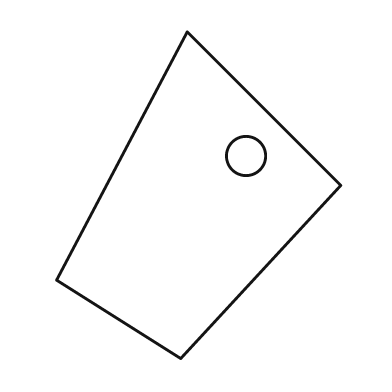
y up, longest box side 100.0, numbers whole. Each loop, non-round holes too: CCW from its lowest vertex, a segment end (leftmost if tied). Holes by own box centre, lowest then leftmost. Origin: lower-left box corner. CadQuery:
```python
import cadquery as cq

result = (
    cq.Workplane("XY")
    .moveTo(38.0, 0.0)
    .lineTo(87.0, 53.0)
    .lineTo(40.0, 100.0)
    .lineTo(0.0, 24.0)
    .close()
    .moveTo(58.0, 62.0)
    .circle(6.0)
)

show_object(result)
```